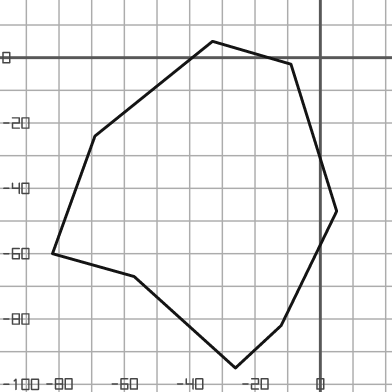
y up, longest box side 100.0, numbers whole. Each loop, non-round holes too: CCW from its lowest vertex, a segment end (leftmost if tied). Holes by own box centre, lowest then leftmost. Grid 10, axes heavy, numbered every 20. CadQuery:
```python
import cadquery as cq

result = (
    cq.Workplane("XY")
    .moveTo(-26.0, -95.0)
    .lineTo(-12.0, -82.0)
    .lineTo(5.0, -47.0)
    .lineTo(-9.0, -2.0)
    .lineTo(-33.0, 5.0)
    .lineTo(-69.0, -24.0)
    .lineTo(-82.0, -60.0)
    .lineTo(-57.0, -67.0)
    .close()
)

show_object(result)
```